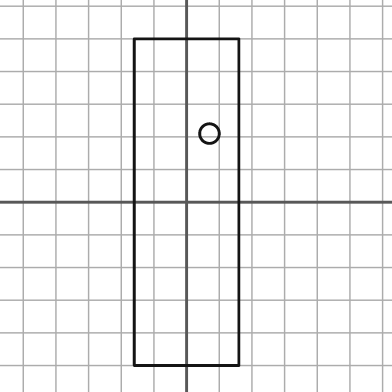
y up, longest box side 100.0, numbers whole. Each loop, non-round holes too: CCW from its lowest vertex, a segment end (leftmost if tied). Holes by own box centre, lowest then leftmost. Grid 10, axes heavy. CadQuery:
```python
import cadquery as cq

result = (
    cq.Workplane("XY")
    .moveTo(-16.0, -50.0)
    .lineTo(16.0, -50.0)
    .lineTo(16.0, 50.0)
    .lineTo(-16.0, 50.0)
    .close()
    .moveTo(7.0, 21.0)
    .circle(3.0)
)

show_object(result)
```